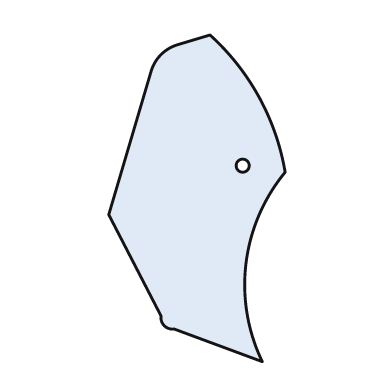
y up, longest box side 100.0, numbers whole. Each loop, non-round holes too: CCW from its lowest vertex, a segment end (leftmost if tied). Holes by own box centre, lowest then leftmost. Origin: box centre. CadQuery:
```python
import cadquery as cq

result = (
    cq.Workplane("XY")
    .moveTo(20.0, -50.0)
    .threePointArc((15.0, -20.0), (27.0, 8.0))
    .threePointArc((19.0, 31.0), (4.0, 50.0))
    .lineTo(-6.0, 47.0)
    .threePointArc((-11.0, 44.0), (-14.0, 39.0))
    .lineTo(-27.0, -5.0)
    .lineTo(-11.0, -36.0)
    .threePointArc((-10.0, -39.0), (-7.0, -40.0))
    .close()
    .moveTo(14.0, 10.0)
    .circle(2.0)
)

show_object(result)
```